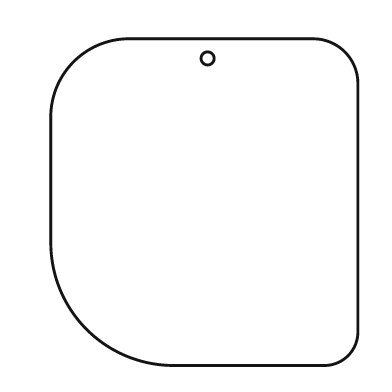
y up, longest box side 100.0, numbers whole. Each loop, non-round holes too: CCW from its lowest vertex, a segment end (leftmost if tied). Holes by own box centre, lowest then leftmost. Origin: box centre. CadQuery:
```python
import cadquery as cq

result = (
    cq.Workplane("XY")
    .moveTo(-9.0, -50.0)
    .lineTo(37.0, -50.0)
    .threePointArc((44.0, -47.0), (47.0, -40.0))
    .lineTo(47.0, 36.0)
    .threePointArc((43.0, 46.0), (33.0, 50.0))
    .lineTo(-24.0, 50.0)
    .threePointArc((-40.0, 43.0), (-47.0, 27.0))
    .lineTo(-47.0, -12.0)
    .threePointArc((-36.0, -39.0), (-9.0, -50.0))
    .close()
    .moveTo(1.0, 44.0)
    .circle(2.0)
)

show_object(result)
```